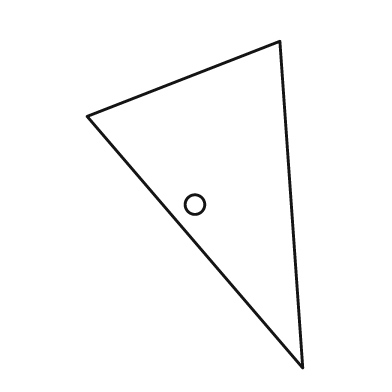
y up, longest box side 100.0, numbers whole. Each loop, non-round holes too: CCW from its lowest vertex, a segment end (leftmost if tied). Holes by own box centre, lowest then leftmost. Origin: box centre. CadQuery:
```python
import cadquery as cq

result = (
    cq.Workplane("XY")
    .moveTo(33.0, -50.0)
    .lineTo(26.0, 50.0)
    .lineTo(-33.0, 27.0)
    .close()
    .moveTo(0.0, 0.0)
    .circle(3.0)
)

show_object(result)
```